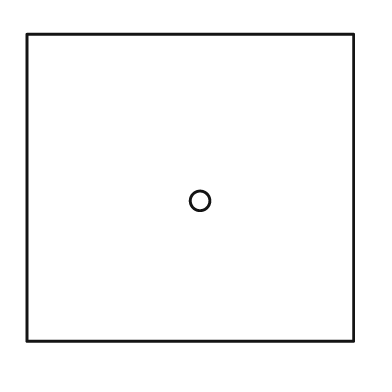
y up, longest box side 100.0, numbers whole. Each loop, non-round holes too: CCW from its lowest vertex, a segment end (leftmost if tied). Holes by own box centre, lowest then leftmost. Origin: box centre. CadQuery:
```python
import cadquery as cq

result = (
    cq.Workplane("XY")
    .moveTo(-50.0, -47.0)
    .lineTo(50.0, -47.0)
    .lineTo(50.0, 47.0)
    .lineTo(-50.0, 47.0)
    .close()
    .moveTo(3.0, -4.0)
    .circle(3.0)
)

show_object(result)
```